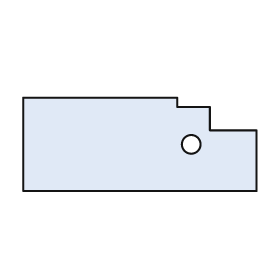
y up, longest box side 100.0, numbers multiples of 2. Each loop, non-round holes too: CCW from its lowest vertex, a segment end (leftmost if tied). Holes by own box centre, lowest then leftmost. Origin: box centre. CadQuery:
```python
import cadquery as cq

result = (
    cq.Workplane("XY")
    .moveTo(-50.0, -20.0)
    .lineTo(50.0, -20.0)
    .lineTo(50.0, 6.0)
    .lineTo(30.0, 6.0)
    .lineTo(30.0, 16.0)
    .lineTo(16.0, 16.0)
    .lineTo(16.0, 20.0)
    .lineTo(-50.0, 20.0)
    .close()
    .moveTo(22.0, 0.0)
    .circle(4.0)
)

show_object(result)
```